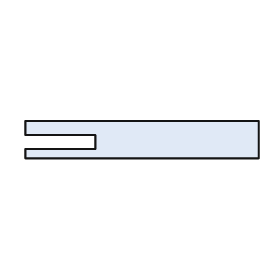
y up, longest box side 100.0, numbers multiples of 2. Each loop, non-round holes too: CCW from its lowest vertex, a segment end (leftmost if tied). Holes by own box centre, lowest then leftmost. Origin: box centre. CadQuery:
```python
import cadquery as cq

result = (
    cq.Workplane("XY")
    .moveTo(-50.0, -8.0)
    .lineTo(50.0, -8.0)
    .lineTo(50.0, 8.0)
    .lineTo(-50.0, 8.0)
    .lineTo(-50.0, 2.0)
    .lineTo(-20.0, 2.0)
    .lineTo(-20.0, -4.0)
    .lineTo(-50.0, -4.0)
    .close()
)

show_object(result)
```